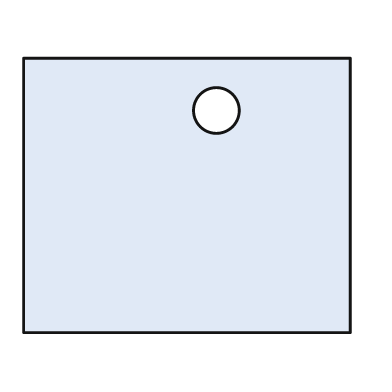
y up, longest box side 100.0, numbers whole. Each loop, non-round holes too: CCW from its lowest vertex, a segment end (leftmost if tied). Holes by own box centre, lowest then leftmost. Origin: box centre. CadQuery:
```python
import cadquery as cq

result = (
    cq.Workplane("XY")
    .moveTo(-50.0, -42.0)
    .lineTo(50.0, -42.0)
    .lineTo(50.0, 42.0)
    .lineTo(-50.0, 42.0)
    .close()
    .moveTo(9.0, 26.0)
    .circle(7.0)
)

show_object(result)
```